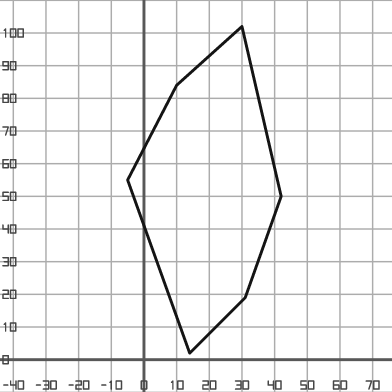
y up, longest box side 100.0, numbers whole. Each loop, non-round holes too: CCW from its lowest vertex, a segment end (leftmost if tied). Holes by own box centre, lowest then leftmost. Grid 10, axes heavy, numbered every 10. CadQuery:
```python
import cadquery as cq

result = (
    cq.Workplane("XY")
    .moveTo(14.0, 2.0)
    .lineTo(31.0, 19.0)
    .lineTo(42.0, 50.0)
    .lineTo(30.0, 102.0)
    .lineTo(10.0, 84.0)
    .lineTo(-5.0, 55.0)
    .close()
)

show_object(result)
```